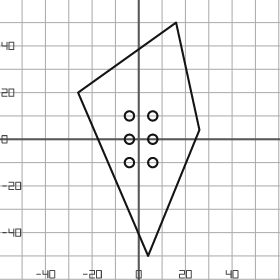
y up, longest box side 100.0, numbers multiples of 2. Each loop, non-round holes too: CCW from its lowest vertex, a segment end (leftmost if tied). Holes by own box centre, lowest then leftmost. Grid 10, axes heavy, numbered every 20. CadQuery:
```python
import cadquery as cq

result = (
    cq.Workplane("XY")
    .moveTo(4.0, -50.0)
    .lineTo(26.0, 4.0)
    .lineTo(16.0, 50.0)
    .lineTo(-26.0, 20.0)
    .close()
    .moveTo(-4.0, -10.0)
    .circle(2.0)
    .moveTo(6.0, -10.0)
    .circle(2.0)
    .moveTo(-4.0, 0.0)
    .circle(2.0)
    .moveTo(6.0, 0.0)
    .circle(2.0)
    .moveTo(-4.0, 10.0)
    .circle(2.0)
    .moveTo(6.0, 10.0)
    .circle(2.0)
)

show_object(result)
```